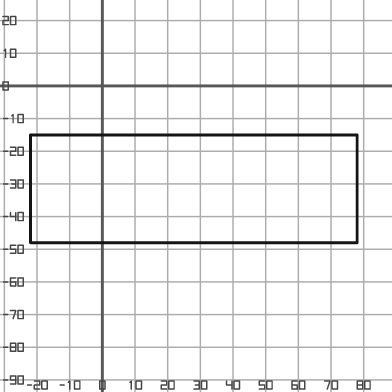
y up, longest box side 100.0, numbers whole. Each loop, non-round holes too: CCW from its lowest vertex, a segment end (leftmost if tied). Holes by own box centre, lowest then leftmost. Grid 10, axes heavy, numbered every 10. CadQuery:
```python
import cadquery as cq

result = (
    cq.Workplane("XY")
    .moveTo(-22.0, -48.0)
    .lineTo(78.0, -48.0)
    .lineTo(78.0, -15.0)
    .lineTo(-22.0, -15.0)
    .close()
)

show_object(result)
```